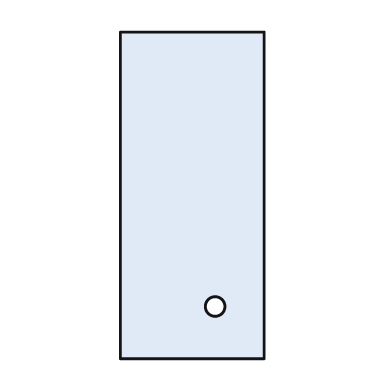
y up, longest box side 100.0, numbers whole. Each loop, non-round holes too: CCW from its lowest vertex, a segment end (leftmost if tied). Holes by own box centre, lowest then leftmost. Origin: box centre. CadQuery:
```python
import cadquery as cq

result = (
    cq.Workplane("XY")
    .moveTo(-22.0, -50.0)
    .lineTo(22.0, -50.0)
    .lineTo(22.0, 50.0)
    .lineTo(-22.0, 50.0)
    .close()
    .moveTo(7.0, -34.0)
    .circle(3.0)
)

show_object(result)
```